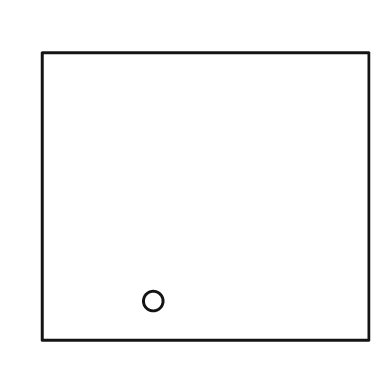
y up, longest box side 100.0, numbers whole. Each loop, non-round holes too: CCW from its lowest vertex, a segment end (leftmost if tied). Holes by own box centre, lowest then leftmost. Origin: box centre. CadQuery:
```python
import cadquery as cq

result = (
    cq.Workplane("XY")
    .moveTo(-50.0, -44.0)
    .lineTo(50.0, -44.0)
    .lineTo(50.0, 44.0)
    .lineTo(-50.0, 44.0)
    .close()
    .moveTo(-16.0, -32.0)
    .circle(3.0)
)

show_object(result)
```